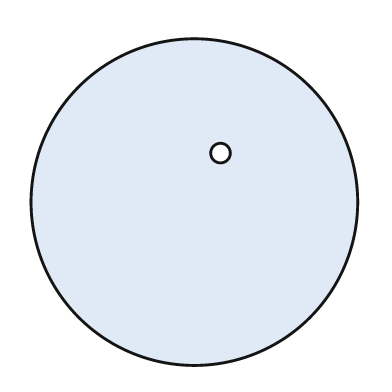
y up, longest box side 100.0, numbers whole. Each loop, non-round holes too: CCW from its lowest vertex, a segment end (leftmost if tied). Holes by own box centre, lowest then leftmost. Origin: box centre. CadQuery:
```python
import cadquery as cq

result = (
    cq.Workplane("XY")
    .moveTo(0.0, 0.0)
    .circle(50.0)
    .moveTo(8.0, 15.0)
    .circle(3.0)
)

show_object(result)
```